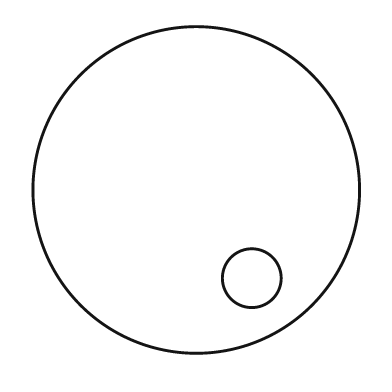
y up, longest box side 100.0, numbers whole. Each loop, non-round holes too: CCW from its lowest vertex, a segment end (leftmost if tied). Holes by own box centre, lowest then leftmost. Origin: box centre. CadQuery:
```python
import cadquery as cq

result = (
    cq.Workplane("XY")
    .moveTo(0.0, 0.0)
    .circle(50.0)
    .moveTo(17.0, -27.0)
    .circle(9.0)
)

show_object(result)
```